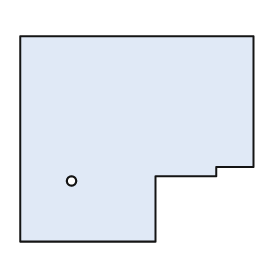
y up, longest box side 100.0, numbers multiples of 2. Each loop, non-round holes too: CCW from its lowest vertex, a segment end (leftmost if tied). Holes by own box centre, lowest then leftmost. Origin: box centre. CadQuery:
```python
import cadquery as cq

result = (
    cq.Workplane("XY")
    .moveTo(-50.0, -44.0)
    .lineTo(8.0, -44.0)
    .lineTo(8.0, -16.0)
    .lineTo(34.0, -16.0)
    .lineTo(34.0, -12.0)
    .lineTo(50.0, -12.0)
    .lineTo(50.0, 44.0)
    .lineTo(-50.0, 44.0)
    .close()
    .moveTo(-28.0, -18.0)
    .circle(2.0)
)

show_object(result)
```